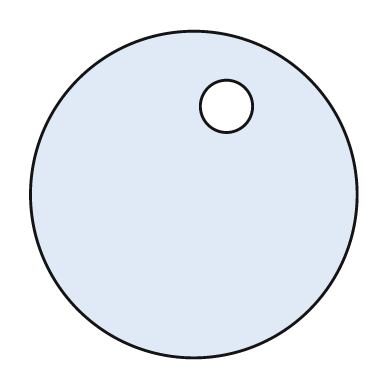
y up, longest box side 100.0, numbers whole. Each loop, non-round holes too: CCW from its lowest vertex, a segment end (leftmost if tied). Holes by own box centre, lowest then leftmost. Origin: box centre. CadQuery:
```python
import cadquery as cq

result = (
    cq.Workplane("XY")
    .moveTo(0.0, 0.0)
    .circle(50.0)
    .moveTo(10.0, 27.0)
    .circle(8.0)
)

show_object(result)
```